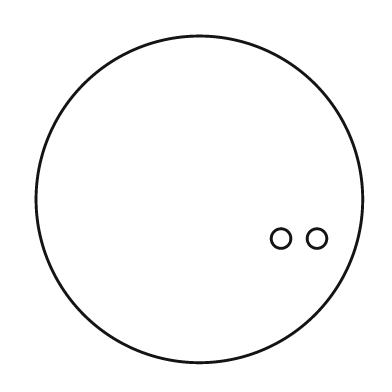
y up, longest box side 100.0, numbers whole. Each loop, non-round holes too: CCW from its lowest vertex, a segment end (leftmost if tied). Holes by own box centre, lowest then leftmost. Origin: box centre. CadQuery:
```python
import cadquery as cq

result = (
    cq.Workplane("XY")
    .moveTo(0.0, 0.0)
    .circle(50.0)
    .moveTo(25.0, -12.0)
    .circle(3.0)
    .moveTo(36.0, -12.0)
    .circle(3.0)
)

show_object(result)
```